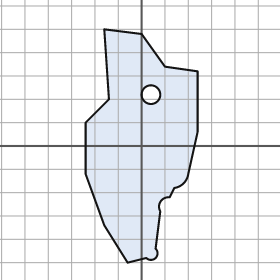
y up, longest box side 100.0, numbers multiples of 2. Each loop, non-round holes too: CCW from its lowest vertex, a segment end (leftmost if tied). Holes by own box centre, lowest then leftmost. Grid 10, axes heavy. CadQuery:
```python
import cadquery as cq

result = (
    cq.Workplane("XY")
    .moveTo(-6.0, -50.0)
    .lineTo(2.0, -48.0)
    .threePointArc((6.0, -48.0), (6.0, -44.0))
    .lineTo(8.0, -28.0)
    .threePointArc((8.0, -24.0), (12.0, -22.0))
    .lineTo(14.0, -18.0)
    .threePointArc((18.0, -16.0), (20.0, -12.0))
    .lineTo(24.0, 6.0)
    .lineTo(24.0, 32.0)
    .lineTo(10.0, 34.0)
    .lineTo(0.0, 48.0)
    .lineTo(-16.0, 50.0)
    .lineTo(-14.0, 20.0)
    .lineTo(-24.0, 10.0)
    .lineTo(-24.0, -12.0)
    .lineTo(-16.0, -34.0)
    .close()
    .moveTo(4.0, 22.0)
    .circle(4.0)
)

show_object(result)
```